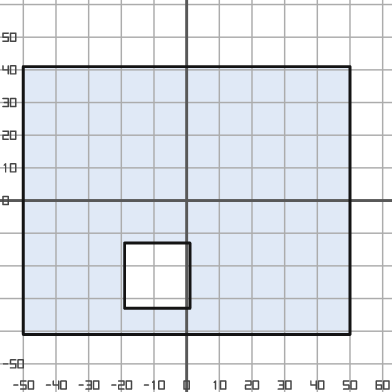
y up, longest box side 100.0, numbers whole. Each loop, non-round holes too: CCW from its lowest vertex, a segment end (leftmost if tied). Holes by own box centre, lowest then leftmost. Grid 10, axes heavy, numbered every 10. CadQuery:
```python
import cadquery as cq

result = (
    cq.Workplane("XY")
    .moveTo(-50.0, -41.0)
    .lineTo(50.0, -41.0)
    .lineTo(50.0, 41.0)
    .lineTo(-50.0, 41.0)
    .close()
    .moveTo(-19.0, -33.0)
    .lineTo(1.0, -33.0)
    .lineTo(1.0, -13.0)
    .lineTo(-19.0, -13.0)
    .close()
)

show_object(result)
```